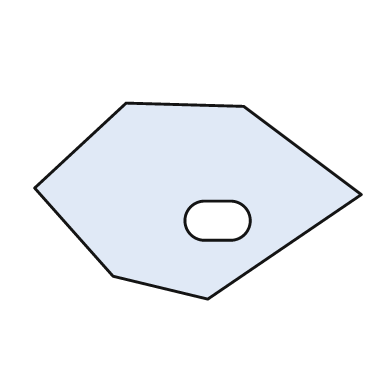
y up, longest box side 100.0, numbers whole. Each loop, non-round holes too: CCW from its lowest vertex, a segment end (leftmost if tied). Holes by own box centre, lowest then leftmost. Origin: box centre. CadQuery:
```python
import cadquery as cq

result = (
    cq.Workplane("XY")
    .moveTo(3.0, -30.0)
    .lineTo(50.0, 2.0)
    .lineTo(14.0, 29.0)
    .lineTo(-22.0, 30.0)
    .lineTo(-50.0, 4.0)
    .lineTo(-26.0, -23.0)
    .close()
    .moveTo(2.0, -12.0)
    .lineTo(10.0, -12.0)
    .threePointArc((16.0, -6.0), (10.0, 0.0))
    .lineTo(2.0, 0.0)
    .threePointArc((-4.0, -6.0), (2.0, -12.0))
    .close()
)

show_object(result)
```